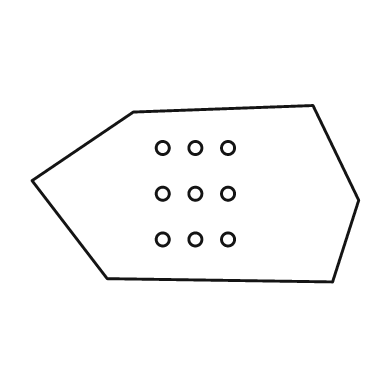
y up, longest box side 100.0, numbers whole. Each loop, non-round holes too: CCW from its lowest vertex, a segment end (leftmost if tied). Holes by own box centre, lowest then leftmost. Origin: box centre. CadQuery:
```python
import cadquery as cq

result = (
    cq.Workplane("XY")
    .moveTo(42.0, -27.0)
    .lineTo(50.0, -2.0)
    .lineTo(36.0, 27.0)
    .lineTo(-19.0, 25.0)
    .lineTo(-50.0, 4.0)
    .lineTo(-27.0, -26.0)
    .close()
    .moveTo(-10.0, -14.0)
    .circle(2.0)
    .moveTo(0.0, -14.0)
    .circle(2.0)
    .moveTo(10.0, -14.0)
    .circle(2.0)
    .moveTo(-10.0, 0.0)
    .circle(2.0)
    .moveTo(0.0, 0.0)
    .circle(2.0)
    .moveTo(10.0, 0.0)
    .circle(2.0)
    .moveTo(-10.0, 14.0)
    .circle(2.0)
    .moveTo(0.0, 14.0)
    .circle(2.0)
    .moveTo(10.0, 14.0)
    .circle(2.0)
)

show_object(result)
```